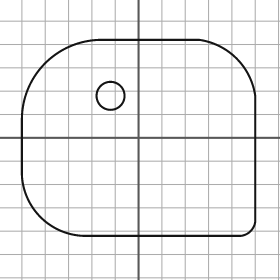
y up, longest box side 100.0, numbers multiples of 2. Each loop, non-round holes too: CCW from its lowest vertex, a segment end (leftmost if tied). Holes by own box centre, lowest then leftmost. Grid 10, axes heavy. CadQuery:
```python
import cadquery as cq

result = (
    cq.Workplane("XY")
    .moveTo(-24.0, -42.0)
    .lineTo(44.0, -42.0)
    .threePointArc((48.0, -40.0), (50.0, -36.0))
    .lineTo(50.0, 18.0)
    .threePointArc((42.0, 34.0), (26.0, 42.0))
    .lineTo(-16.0, 42.0)
    .threePointArc((-40.0, 32.0), (-50.0, 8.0))
    .lineTo(-50.0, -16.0)
    .threePointArc((-42.0, -34.0), (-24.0, -42.0))
    .close()
    .moveTo(-12.0, 18.0)
    .circle(6.0)
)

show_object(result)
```